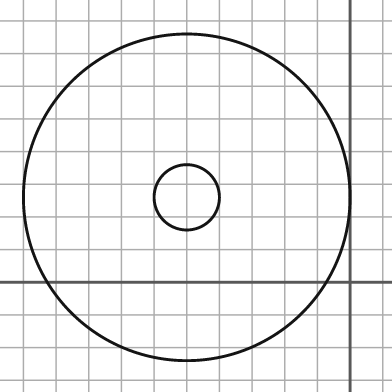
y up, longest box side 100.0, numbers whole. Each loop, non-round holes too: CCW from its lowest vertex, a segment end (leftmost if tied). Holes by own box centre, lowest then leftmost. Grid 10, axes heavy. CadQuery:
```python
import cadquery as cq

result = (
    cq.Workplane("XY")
    .moveTo(-50.0, 26.0)
    .circle(50.0)
    .moveTo(-50.0, 26.0)
    .circle(10.0)
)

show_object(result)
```